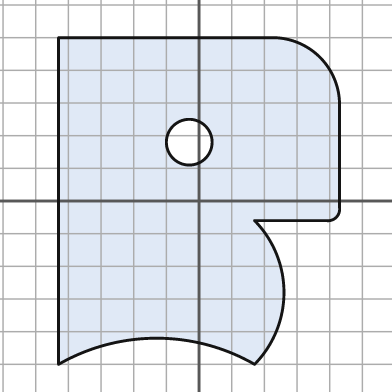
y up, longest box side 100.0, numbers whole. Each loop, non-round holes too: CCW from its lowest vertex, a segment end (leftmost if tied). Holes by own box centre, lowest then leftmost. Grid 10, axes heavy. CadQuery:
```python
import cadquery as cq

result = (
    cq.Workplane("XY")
    .moveTo(-43.0, -50.0)
    .threePointArc((-13.0, -42.0), (17.0, -50.0))
    .threePointArc((26.0, -28.0), (17.0, -6.0))
    .lineTo(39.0, -6.0)
    .threePointArc((42.0, -5.0), (43.0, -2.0))
    .lineTo(43.0, 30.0)
    .threePointArc((37.0, 44.0), (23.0, 50.0))
    .lineTo(-43.0, 50.0)
    .close()
    .moveTo(-3.0, 18.0)
    .circle(7.0)
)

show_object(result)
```